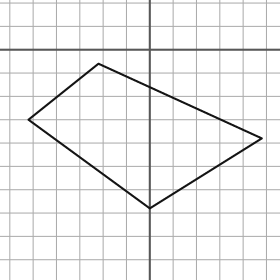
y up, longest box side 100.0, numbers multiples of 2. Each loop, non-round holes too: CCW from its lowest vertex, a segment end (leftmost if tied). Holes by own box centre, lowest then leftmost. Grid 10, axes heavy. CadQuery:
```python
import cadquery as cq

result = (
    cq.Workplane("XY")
    .moveTo(0.0, -68.0)
    .lineTo(48.0, -38.0)
    .lineTo(-22.0, -6.0)
    .lineTo(-52.0, -30.0)
    .close()
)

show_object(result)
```